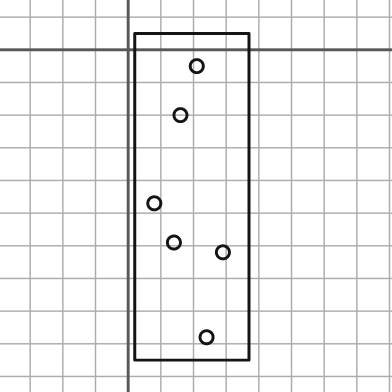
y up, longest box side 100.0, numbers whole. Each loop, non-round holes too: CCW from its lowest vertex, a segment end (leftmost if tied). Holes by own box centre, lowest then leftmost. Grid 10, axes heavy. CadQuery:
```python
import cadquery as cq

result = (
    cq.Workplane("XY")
    .moveTo(2.0, -95.0)
    .lineTo(37.0, -95.0)
    .lineTo(37.0, 5.0)
    .lineTo(2.0, 5.0)
    .close()
    .moveTo(24.0, -88.0)
    .circle(2.0)
    .moveTo(29.0, -62.0)
    .circle(2.0)
    .moveTo(14.0, -59.0)
    .circle(2.0)
    .moveTo(8.0, -47.0)
    .circle(2.0)
    .moveTo(16.0, -20.0)
    .circle(2.0)
    .moveTo(21.0, -5.0)
    .circle(2.0)
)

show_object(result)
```